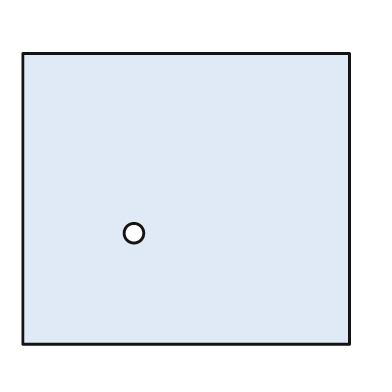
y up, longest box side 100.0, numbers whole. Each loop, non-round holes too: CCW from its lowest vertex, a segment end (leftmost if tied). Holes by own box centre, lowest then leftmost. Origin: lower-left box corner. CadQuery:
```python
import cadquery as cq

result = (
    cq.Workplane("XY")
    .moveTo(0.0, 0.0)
    .lineTo(100.0, 0.0)
    .lineTo(100.0, 89.0)
    .lineTo(0.0, 89.0)
    .close()
    .moveTo(34.0, 34.0)
    .circle(3.0)
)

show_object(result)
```